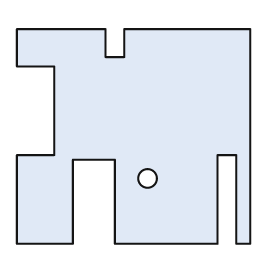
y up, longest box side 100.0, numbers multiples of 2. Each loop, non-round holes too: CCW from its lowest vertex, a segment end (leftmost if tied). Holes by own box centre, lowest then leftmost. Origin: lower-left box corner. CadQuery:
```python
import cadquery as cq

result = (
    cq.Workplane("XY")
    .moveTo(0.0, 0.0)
    .lineTo(24.0, 0.0)
    .lineTo(24.0, 36.0)
    .lineTo(42.0, 36.0)
    .lineTo(42.0, 0.0)
    .lineTo(86.0, 0.0)
    .lineTo(86.0, 38.0)
    .lineTo(94.0, 38.0)
    .lineTo(94.0, 0.0)
    .lineTo(100.0, 0.0)
    .lineTo(100.0, 92.0)
    .lineTo(46.0, 92.0)
    .lineTo(46.0, 80.0)
    .lineTo(38.0, 80.0)
    .lineTo(38.0, 92.0)
    .lineTo(0.0, 92.0)
    .lineTo(0.0, 76.0)
    .lineTo(16.0, 76.0)
    .lineTo(16.0, 38.0)
    .lineTo(0.0, 38.0)
    .close()
    .moveTo(56.0, 28.0)
    .circle(4.0)
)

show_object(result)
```